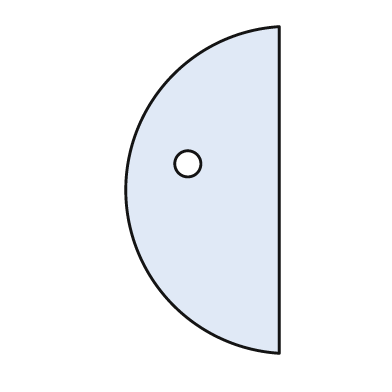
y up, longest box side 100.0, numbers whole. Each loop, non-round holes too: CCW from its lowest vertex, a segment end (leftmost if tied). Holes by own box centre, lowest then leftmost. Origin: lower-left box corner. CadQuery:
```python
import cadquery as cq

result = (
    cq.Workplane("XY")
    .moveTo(47.0, 0.0)
    .lineTo(47.0, 100.0)
    .threePointArc((0.0, 50.0), (47.0, 0.0))
    .close()
    .moveTo(19.0, 58.0)
    .circle(4.0)
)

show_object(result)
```